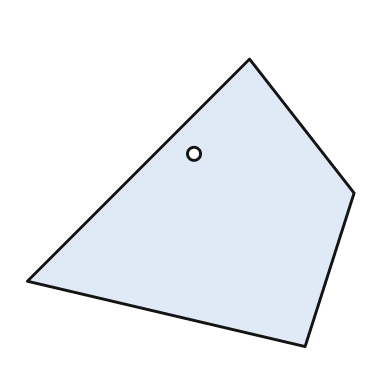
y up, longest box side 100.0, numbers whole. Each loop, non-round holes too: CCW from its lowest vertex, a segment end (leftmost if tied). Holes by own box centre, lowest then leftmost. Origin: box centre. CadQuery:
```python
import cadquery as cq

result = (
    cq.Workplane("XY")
    .moveTo(35.0, -44.0)
    .lineTo(50.0, 3.0)
    .lineTo(18.0, 44.0)
    .lineTo(-50.0, -24.0)
    .close()
    .moveTo(1.0, 15.0)
    .circle(2.0)
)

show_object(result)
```